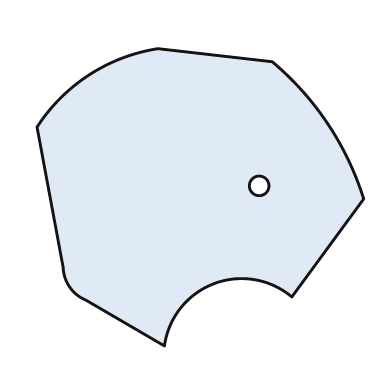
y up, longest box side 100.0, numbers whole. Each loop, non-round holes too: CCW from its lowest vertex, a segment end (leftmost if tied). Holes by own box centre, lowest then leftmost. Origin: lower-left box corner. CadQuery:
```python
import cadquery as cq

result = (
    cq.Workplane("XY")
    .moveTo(39.0, 0.0)
    .threePointArc((54.0, 19.0), (78.0, 15.0))
    .lineTo(100.0, 45.0)
    .threePointArc((89.0, 68.0), (72.0, 87.0))
    .lineTo(37.0, 91.0)
    .threePointArc((16.0, 83.0), (0.0, 67.0))
    .lineTo(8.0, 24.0)
    .threePointArc((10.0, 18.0), (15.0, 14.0))
    .close()
    .moveTo(68.0, 49.0)
    .circle(3.0)
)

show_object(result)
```